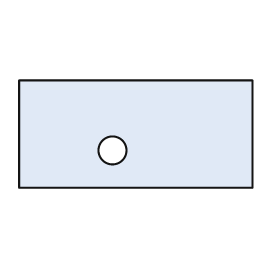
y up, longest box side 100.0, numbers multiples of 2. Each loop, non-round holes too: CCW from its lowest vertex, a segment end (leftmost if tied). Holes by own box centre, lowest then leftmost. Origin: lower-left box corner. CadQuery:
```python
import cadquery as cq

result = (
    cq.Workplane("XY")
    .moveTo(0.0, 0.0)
    .lineTo(100.0, 0.0)
    .lineTo(100.0, 46.0)
    .lineTo(0.0, 46.0)
    .close()
    .moveTo(40.0, 16.0)
    .circle(6.0)
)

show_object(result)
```